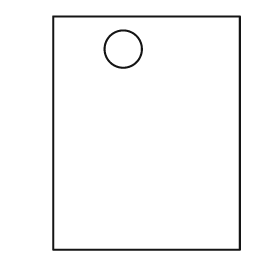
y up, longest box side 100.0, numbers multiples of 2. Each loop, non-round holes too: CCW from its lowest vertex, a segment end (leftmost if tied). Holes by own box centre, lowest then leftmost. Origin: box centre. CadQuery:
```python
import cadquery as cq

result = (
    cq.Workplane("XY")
    .moveTo(-40.0, -50.0)
    .lineTo(40.0, -50.0)
    .lineTo(40.0, 50.0)
    .lineTo(-40.0, 50.0)
    .close()
    .moveTo(-10.0, 36.0)
    .circle(8.0)
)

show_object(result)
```